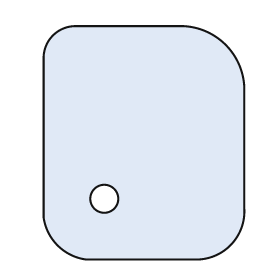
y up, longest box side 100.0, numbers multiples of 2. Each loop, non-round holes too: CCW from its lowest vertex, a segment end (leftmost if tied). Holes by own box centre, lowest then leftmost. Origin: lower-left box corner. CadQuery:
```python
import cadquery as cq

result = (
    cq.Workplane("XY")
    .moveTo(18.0, 0.0)
    .lineTo(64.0, 0.0)
    .threePointArc((80.0, 6.0), (86.0, 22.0))
    .lineTo(86.0, 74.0)
    .threePointArc((78.0, 92.0), (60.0, 100.0))
    .lineTo(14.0, 100.0)
    .threePointArc((4.0, 96.0), (0.0, 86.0))
    .lineTo(0.0, 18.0)
    .threePointArc((6.0, 6.0), (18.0, 0.0))
    .close()
    .moveTo(26.0, 26.0)
    .circle(6.0)
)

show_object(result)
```